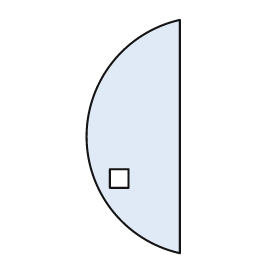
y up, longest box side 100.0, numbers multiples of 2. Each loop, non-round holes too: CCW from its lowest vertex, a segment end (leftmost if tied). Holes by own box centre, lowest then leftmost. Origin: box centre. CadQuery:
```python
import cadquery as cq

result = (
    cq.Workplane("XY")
    .moveTo(20.0, -50.0)
    .lineTo(20.0, 50.0)
    .threePointArc((-20.0, 0.0), (20.0, -50.0))
    .close()
    .moveTo(-10.0, -22.0)
    .lineTo(-2.0, -22.0)
    .lineTo(-2.0, -14.0)
    .lineTo(-10.0, -14.0)
    .close()
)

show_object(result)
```